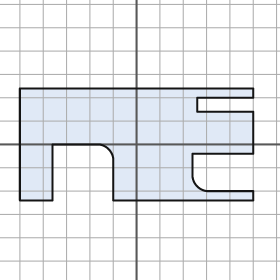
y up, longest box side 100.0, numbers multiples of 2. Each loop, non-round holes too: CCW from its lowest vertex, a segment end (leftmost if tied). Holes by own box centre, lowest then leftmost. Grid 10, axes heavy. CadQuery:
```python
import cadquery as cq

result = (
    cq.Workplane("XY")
    .moveTo(-50.0, -24.0)
    .lineTo(-36.0, -24.0)
    .lineTo(-36.0, 0.0)
    .lineTo(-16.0, 0.0)
    .threePointArc((-12.0, -2.0), (-10.0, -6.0))
    .lineTo(-10.0, -24.0)
    .lineTo(50.0, -24.0)
    .lineTo(50.0, -20.0)
    .lineTo(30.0, -20.0)
    .threePointArc((26.0, -18.0), (24.0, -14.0))
    .lineTo(24.0, -4.0)
    .lineTo(50.0, -4.0)
    .lineTo(50.0, 14.0)
    .lineTo(26.0, 14.0)
    .lineTo(26.0, 20.0)
    .lineTo(50.0, 20.0)
    .lineTo(50.0, 24.0)
    .lineTo(-50.0, 24.0)
    .close()
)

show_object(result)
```